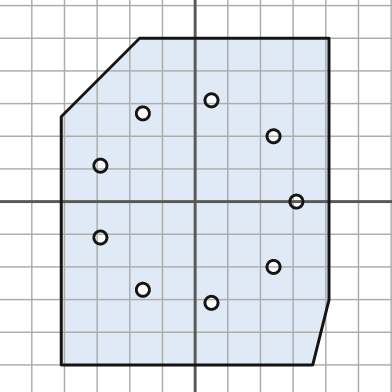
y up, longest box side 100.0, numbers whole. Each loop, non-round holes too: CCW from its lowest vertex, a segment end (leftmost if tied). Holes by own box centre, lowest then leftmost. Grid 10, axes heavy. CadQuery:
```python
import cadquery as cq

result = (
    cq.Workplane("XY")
    .moveTo(-41.0, -50.0)
    .lineTo(36.0, -50.0)
    .lineTo(41.0, -30.0)
    .lineTo(41.0, 50.0)
    .lineTo(-17.0, 50.0)
    .lineTo(-41.0, 26.0)
    .close()
    .moveTo(5.0, -31.0)
    .circle(2.0)
    .moveTo(-16.0, -27.0)
    .circle(2.0)
    .moveTo(24.0, -20.0)
    .circle(2.0)
    .moveTo(-29.0, -11.0)
    .circle(2.0)
    .moveTo(31.0, 0.0)
    .circle(2.0)
    .moveTo(-29.0, 11.0)
    .circle(2.0)
    .moveTo(24.0, 20.0)
    .circle(2.0)
    .moveTo(-16.0, 27.0)
    .circle(2.0)
    .moveTo(5.0, 31.0)
    .circle(2.0)
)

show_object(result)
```